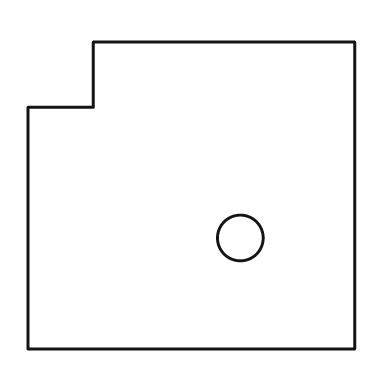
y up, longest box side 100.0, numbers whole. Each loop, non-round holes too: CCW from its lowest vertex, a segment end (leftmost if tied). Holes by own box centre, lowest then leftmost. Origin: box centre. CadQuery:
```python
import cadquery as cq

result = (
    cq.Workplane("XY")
    .moveTo(-50.0, -47.0)
    .lineTo(50.0, -47.0)
    .lineTo(50.0, 47.0)
    .lineTo(-30.0, 47.0)
    .lineTo(-30.0, 27.0)
    .lineTo(-50.0, 27.0)
    .close()
    .moveTo(15.0, -13.0)
    .circle(7.0)
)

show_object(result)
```